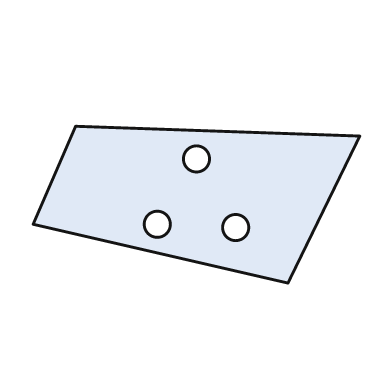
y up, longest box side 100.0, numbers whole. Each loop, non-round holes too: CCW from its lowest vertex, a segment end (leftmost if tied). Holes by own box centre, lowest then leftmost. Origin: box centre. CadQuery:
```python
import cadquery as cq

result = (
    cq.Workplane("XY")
    .moveTo(28.0, -24.0)
    .lineTo(50.0, 21.0)
    .lineTo(-37.0, 24.0)
    .lineTo(-50.0, -6.0)
    .close()
    .moveTo(12.0, -7.0)
    .circle(4.0)
    .moveTo(-12.0, -6.0)
    .circle(4.0)
    .moveTo(0.0, 14.0)
    .circle(4.0)
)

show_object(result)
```